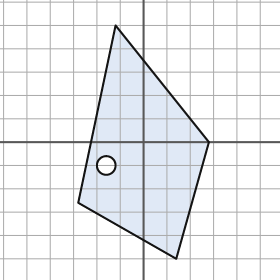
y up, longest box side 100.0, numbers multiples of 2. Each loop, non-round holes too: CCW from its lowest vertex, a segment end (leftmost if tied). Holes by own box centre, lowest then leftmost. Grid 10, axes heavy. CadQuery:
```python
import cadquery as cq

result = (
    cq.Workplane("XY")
    .moveTo(14.0, -50.0)
    .lineTo(28.0, 0.0)
    .lineTo(-12.0, 50.0)
    .lineTo(-28.0, -26.0)
    .close()
    .moveTo(-16.0, -10.0)
    .circle(4.0)
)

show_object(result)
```